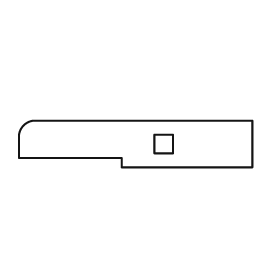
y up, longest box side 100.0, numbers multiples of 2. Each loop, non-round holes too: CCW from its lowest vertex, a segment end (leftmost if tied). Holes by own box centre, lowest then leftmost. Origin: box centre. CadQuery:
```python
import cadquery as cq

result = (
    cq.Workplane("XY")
    .moveTo(-6.0, -10.0)
    .lineTo(50.0, -10.0)
    .lineTo(50.0, 10.0)
    .lineTo(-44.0, 10.0)
    .threePointArc((-48.0, 8.0), (-50.0, 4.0))
    .lineTo(-50.0, -6.0)
    .lineTo(-6.0, -6.0)
    .close()
    .moveTo(8.0, -4.0)
    .lineTo(16.0, -4.0)
    .lineTo(16.0, 4.0)
    .lineTo(8.0, 4.0)
    .close()
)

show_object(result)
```